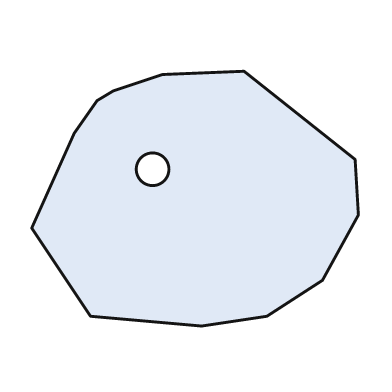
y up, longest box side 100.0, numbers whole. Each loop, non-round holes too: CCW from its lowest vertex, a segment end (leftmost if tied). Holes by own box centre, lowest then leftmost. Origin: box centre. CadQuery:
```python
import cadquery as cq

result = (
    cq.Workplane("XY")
    .moveTo(2.0, -39.0)
    .lineTo(22.0, -36.0)
    .lineTo(39.0, -25.0)
    .lineTo(50.0, -5.0)
    .lineTo(49.0, 12.0)
    .lineTo(15.0, 39.0)
    .lineTo(-10.0, 38.0)
    .lineTo(-25.0, 33.0)
    .lineTo(-30.0, 30.0)
    .lineTo(-37.0, 20.0)
    .lineTo(-50.0, -9.0)
    .lineTo(-32.0, -36.0)
    .close()
    .moveTo(-13.0, 9.0)
    .circle(5.0)
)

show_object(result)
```